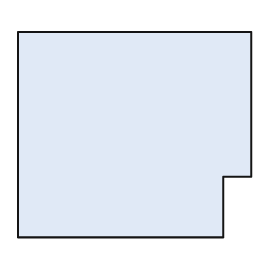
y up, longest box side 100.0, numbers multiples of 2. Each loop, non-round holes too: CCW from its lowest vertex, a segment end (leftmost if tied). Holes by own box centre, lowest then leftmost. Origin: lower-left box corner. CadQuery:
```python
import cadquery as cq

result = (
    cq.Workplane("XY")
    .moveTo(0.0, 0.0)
    .lineTo(88.0, 0.0)
    .lineTo(88.0, 26.0)
    .lineTo(100.0, 26.0)
    .lineTo(100.0, 88.0)
    .lineTo(0.0, 88.0)
    .close()
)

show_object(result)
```